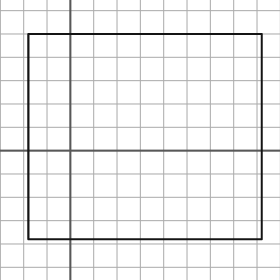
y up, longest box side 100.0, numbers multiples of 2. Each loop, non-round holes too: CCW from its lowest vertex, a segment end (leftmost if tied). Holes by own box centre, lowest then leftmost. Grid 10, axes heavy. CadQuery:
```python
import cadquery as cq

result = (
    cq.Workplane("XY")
    .moveTo(-18.0, -38.0)
    .lineTo(82.0, -38.0)
    .lineTo(82.0, 50.0)
    .lineTo(-18.0, 50.0)
    .close()
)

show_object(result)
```